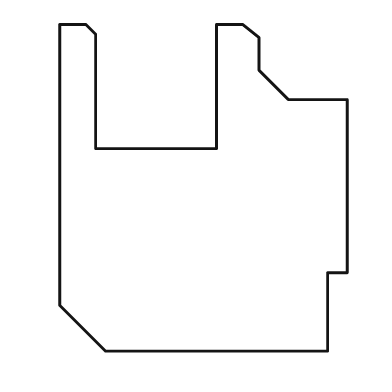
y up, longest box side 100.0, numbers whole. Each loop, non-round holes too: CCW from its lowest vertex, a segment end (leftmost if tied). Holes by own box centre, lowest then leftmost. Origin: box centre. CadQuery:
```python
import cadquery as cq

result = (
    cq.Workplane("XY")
    .moveTo(-30.0, -50.0)
    .lineTo(38.0, -50.0)
    .lineTo(38.0, -26.0)
    .lineTo(44.0, -26.0)
    .lineTo(44.0, 27.0)
    .lineTo(26.0, 27.0)
    .lineTo(17.0, 36.0)
    .lineTo(17.0, 46.0)
    .lineTo(12.0, 50.0)
    .lineTo(4.0, 50.0)
    .lineTo(4.0, 12.0)
    .lineTo(-33.0, 12.0)
    .lineTo(-33.0, 47.0)
    .lineTo(-36.0, 50.0)
    .lineTo(-44.0, 50.0)
    .lineTo(-44.0, -36.0)
    .close()
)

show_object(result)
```